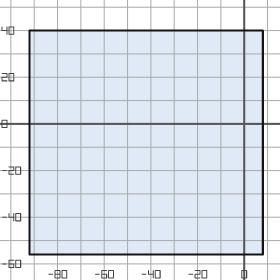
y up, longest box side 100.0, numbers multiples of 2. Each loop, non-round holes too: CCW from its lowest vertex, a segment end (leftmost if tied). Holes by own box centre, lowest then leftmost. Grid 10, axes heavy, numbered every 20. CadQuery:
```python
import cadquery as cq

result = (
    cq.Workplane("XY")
    .moveTo(-92.0, -56.0)
    .lineTo(8.0, -56.0)
    .lineTo(8.0, 40.0)
    .lineTo(-92.0, 40.0)
    .close()
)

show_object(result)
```